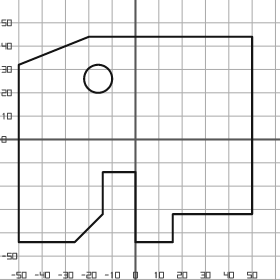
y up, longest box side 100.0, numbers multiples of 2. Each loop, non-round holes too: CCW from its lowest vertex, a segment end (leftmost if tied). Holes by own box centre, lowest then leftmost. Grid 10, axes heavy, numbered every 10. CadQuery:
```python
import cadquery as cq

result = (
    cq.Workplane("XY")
    .moveTo(-50.0, -44.0)
    .lineTo(-26.0, -44.0)
    .lineTo(-14.0, -32.0)
    .lineTo(-14.0, -14.0)
    .lineTo(0.0, -14.0)
    .lineTo(0.0, -44.0)
    .lineTo(16.0, -44.0)
    .lineTo(16.0, -32.0)
    .lineTo(50.0, -32.0)
    .lineTo(50.0, 44.0)
    .lineTo(-20.0, 44.0)
    .lineTo(-50.0, 32.0)
    .close()
    .moveTo(-16.0, 26.0)
    .circle(6.0)
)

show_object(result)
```